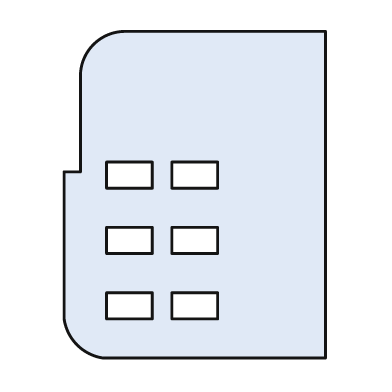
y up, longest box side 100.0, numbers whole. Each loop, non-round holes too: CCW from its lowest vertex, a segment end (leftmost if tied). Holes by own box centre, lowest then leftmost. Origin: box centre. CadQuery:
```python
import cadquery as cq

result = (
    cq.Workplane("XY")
    .moveTo(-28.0, -50.0)
    .lineTo(40.0, -50.0)
    .lineTo(40.0, 50.0)
    .lineTo(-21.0, 50.0)
    .threePointArc((-31.0, 46.0), (-35.0, 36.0))
    .lineTo(-35.0, 7.0)
    .lineTo(-40.0, 7.0)
    .lineTo(-40.0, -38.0)
    .threePointArc((-36.0, -46.0), (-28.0, -50.0))
    .close()
    .moveTo(-27.0, -38.0)
    .lineTo(-13.0, -38.0)
    .lineTo(-13.0, -30.0)
    .lineTo(-27.0, -30.0)
    .close()
    .moveTo(-7.0, -38.0)
    .lineTo(7.0, -38.0)
    .lineTo(7.0, -30.0)
    .lineTo(-7.0, -30.0)
    .close()
    .moveTo(-27.0, -18.0)
    .lineTo(-13.0, -18.0)
    .lineTo(-13.0, -10.0)
    .lineTo(-27.0, -10.0)
    .close()
    .moveTo(-7.0, -18.0)
    .lineTo(7.0, -18.0)
    .lineTo(7.0, -10.0)
    .lineTo(-7.0, -10.0)
    .close()
    .moveTo(-27.0, 2.0)
    .lineTo(-13.0, 2.0)
    .lineTo(-13.0, 10.0)
    .lineTo(-27.0, 10.0)
    .close()
    .moveTo(-7.0, 2.0)
    .lineTo(7.0, 2.0)
    .lineTo(7.0, 10.0)
    .lineTo(-7.0, 10.0)
    .close()
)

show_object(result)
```